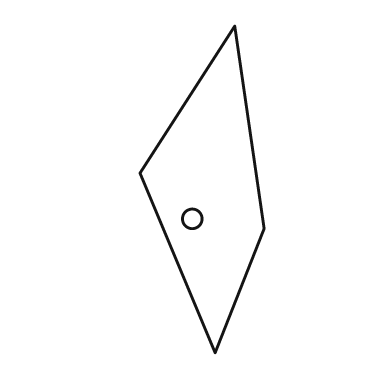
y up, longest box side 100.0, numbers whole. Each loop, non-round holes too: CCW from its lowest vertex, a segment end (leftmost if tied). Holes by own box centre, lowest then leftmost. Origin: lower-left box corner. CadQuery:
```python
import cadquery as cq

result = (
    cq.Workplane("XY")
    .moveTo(23.0, 0.0)
    .lineTo(38.0, 38.0)
    .lineTo(29.0, 100.0)
    .lineTo(0.0, 55.0)
    .close()
    .moveTo(16.0, 41.0)
    .circle(3.0)
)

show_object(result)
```